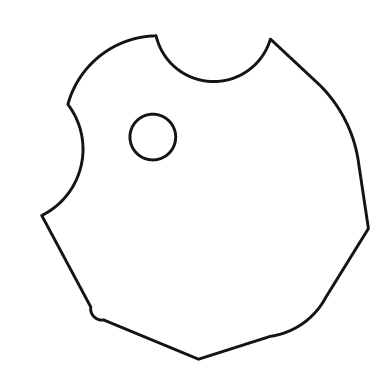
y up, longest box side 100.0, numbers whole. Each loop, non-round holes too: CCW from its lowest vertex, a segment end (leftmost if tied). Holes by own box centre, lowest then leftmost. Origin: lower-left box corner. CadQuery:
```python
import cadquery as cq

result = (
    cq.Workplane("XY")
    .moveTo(48.0, 0.0)
    .lineTo(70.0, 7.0)
    .threePointArc((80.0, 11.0), (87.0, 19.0))
    .lineTo(100.0, 40.0)
    .lineTo(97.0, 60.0)
    .threePointArc((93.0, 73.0), (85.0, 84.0))
    .lineTo(70.0, 98.0)
    .threePointArc((52.0, 85.0), (35.0, 99.0))
    .threePointArc((18.0, 93.0), (8.0, 78.0))
    .threePointArc((12.0, 59.0), (0.0, 44.0))
    .lineTo(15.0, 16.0)
    .threePointArc((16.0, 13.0), (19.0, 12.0))
    .close()
    .moveTo(34.0, 68.0)
    .circle(7.0)
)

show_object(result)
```